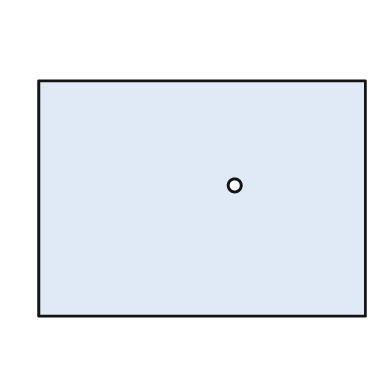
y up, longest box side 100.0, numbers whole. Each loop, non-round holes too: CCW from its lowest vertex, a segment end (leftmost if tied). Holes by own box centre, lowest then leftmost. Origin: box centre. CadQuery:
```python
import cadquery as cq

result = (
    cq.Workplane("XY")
    .moveTo(-50.0, -36.0)
    .lineTo(50.0, -36.0)
    .lineTo(50.0, 36.0)
    .lineTo(-50.0, 36.0)
    .close()
    .moveTo(10.0, 4.0)
    .circle(2.0)
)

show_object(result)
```